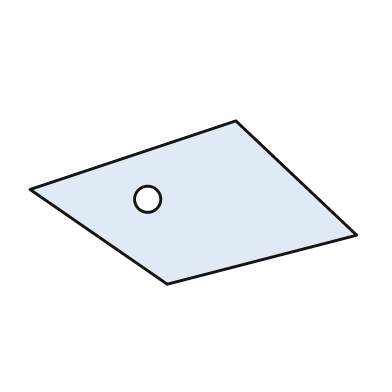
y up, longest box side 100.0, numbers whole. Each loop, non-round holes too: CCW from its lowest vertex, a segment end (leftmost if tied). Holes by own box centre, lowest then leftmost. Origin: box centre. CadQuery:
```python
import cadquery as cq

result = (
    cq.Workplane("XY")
    .moveTo(-8.0, -25.0)
    .lineTo(50.0, -10.0)
    .lineTo(13.0, 25.0)
    .lineTo(-50.0, 4.0)
    .close()
    .moveTo(-14.0, 1.0)
    .circle(4.0)
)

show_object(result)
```